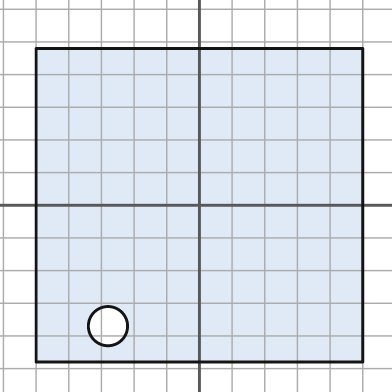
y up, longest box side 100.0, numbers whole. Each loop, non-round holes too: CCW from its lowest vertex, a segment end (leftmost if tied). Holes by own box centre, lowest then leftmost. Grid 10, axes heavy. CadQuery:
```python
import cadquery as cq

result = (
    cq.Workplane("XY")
    .moveTo(-50.0, -48.0)
    .lineTo(50.0, -48.0)
    .lineTo(50.0, 48.0)
    .lineTo(-50.0, 48.0)
    .close()
    .moveTo(-28.0, -37.0)
    .circle(6.0)
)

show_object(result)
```